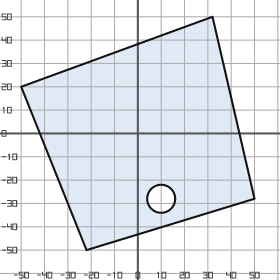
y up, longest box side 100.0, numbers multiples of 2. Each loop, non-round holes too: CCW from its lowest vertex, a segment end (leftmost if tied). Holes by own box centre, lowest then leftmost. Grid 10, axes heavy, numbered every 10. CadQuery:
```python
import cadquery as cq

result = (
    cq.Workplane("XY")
    .moveTo(-22.0, -50.0)
    .lineTo(50.0, -28.0)
    .lineTo(32.0, 50.0)
    .lineTo(-50.0, 20.0)
    .close()
    .moveTo(10.0, -28.0)
    .circle(6.0)
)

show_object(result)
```